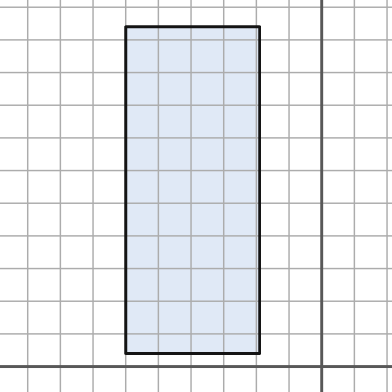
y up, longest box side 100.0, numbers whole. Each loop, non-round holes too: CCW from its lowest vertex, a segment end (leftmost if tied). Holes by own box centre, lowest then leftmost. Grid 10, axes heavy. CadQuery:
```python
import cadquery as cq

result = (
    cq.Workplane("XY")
    .moveTo(-60.0, 4.0)
    .lineTo(-19.0, 4.0)
    .lineTo(-19.0, 104.0)
    .lineTo(-60.0, 104.0)
    .close()
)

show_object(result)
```